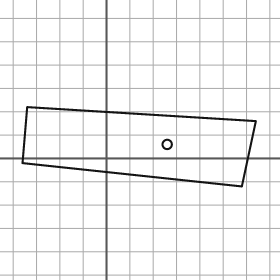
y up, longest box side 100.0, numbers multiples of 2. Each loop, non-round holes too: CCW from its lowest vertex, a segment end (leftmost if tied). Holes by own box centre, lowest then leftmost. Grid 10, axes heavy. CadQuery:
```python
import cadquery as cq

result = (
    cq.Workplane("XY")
    .moveTo(58.0, -12.0)
    .lineTo(64.0, 16.0)
    .lineTo(-34.0, 22.0)
    .lineTo(-36.0, -2.0)
    .close()
    .moveTo(26.0, 6.0)
    .circle(2.0)
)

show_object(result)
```